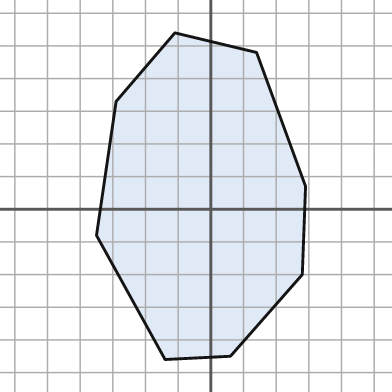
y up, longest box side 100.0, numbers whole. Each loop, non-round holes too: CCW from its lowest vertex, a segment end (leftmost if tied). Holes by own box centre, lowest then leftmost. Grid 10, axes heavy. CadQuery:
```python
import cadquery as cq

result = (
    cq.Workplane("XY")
    .moveTo(-14.0, -46.0)
    .lineTo(6.0, -45.0)
    .lineTo(28.0, -20.0)
    .lineTo(29.0, 7.0)
    .lineTo(14.0, 48.0)
    .lineTo(-11.0, 54.0)
    .lineTo(-29.0, 33.0)
    .lineTo(-35.0, -8.0)
    .close()
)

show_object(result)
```